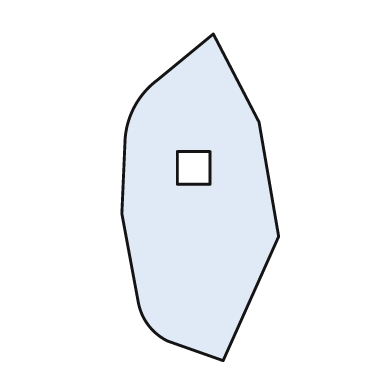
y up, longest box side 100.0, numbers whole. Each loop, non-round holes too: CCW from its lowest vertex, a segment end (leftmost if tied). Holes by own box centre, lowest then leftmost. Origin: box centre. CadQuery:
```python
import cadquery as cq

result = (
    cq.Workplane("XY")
    .moveTo(7.0, -50.0)
    .lineTo(24.0, -12.0)
    .lineTo(18.0, 23.0)
    .lineTo(4.0, 50.0)
    .lineTo(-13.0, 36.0)
    .threePointArc((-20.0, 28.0), (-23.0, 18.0))
    .lineTo(-24.0, -5.0)
    .lineTo(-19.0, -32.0)
    .threePointArc((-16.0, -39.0), (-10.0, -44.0))
    .close()
    .moveTo(-7.0, 4.0)
    .lineTo(3.0, 4.0)
    .lineTo(3.0, 14.0)
    .lineTo(-7.0, 14.0)
    .close()
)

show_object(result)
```